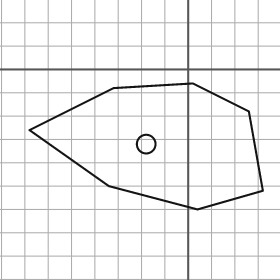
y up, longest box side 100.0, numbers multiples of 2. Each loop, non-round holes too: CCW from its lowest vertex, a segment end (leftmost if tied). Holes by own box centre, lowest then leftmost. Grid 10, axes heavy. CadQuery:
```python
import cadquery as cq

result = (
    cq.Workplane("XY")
    .moveTo(4.0, -60.0)
    .lineTo(32.0, -52.0)
    .lineTo(26.0, -18.0)
    .lineTo(2.0, -6.0)
    .lineTo(-32.0, -8.0)
    .lineTo(-68.0, -26.0)
    .lineTo(-34.0, -50.0)
    .close()
    .moveTo(-18.0, -32.0)
    .circle(4.0)
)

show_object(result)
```